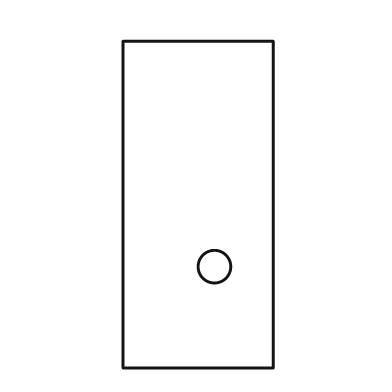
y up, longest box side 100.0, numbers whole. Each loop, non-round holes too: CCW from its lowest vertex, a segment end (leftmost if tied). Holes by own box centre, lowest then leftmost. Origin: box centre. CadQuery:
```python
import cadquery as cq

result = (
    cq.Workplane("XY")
    .moveTo(-23.0, -50.0)
    .lineTo(23.0, -50.0)
    .lineTo(23.0, 50.0)
    .lineTo(-23.0, 50.0)
    .close()
    .moveTo(5.0, -19.0)
    .circle(5.0)
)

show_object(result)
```